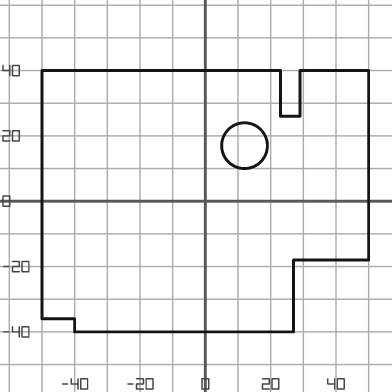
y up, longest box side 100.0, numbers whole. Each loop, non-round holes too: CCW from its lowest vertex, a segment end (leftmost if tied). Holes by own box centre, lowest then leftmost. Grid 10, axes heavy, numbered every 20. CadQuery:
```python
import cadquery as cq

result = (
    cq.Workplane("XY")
    .moveTo(-40.0, -40.0)
    .lineTo(27.0, -40.0)
    .lineTo(27.0, -18.0)
    .lineTo(50.0, -18.0)
    .lineTo(50.0, 40.0)
    .lineTo(29.0, 40.0)
    .lineTo(29.0, 26.0)
    .lineTo(23.0, 26.0)
    .lineTo(23.0, 40.0)
    .lineTo(-50.0, 40.0)
    .lineTo(-50.0, -36.0)
    .lineTo(-40.0, -36.0)
    .close()
    .moveTo(12.0, 17.0)
    .circle(7.0)
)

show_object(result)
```